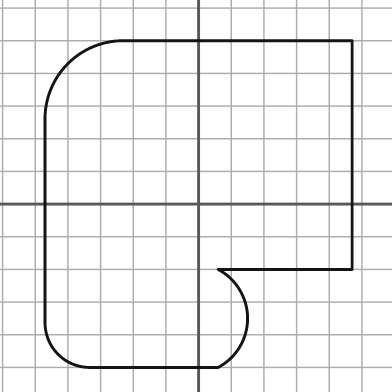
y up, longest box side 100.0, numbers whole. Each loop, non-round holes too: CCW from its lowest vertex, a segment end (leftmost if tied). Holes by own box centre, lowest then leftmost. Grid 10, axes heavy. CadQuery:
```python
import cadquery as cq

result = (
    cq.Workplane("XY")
    .moveTo(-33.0, -50.0)
    .lineTo(6.0, -50.0)
    .threePointArc((15.0, -35.0), (6.0, -20.0))
    .lineTo(47.0, -20.0)
    .lineTo(47.0, 50.0)
    .lineTo(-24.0, 50.0)
    .threePointArc((-40.0, 43.0), (-47.0, 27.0))
    .lineTo(-47.0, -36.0)
    .threePointArc((-43.0, -46.0), (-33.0, -50.0))
    .close()
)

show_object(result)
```